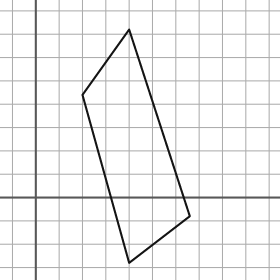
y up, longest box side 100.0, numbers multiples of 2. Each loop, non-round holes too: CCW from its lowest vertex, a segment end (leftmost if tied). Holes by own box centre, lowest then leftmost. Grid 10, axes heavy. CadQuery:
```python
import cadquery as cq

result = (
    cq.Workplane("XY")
    .moveTo(40.0, -28.0)
    .lineTo(66.0, -8.0)
    .lineTo(40.0, 72.0)
    .lineTo(20.0, 44.0)
    .close()
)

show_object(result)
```